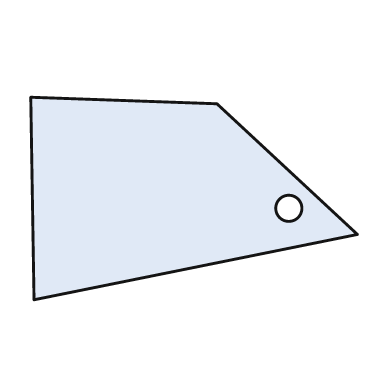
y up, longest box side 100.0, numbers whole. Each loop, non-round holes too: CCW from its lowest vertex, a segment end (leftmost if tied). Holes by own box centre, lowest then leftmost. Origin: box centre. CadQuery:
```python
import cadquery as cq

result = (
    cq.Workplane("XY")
    .moveTo(-49.0, -31.0)
    .lineTo(50.0, -11.0)
    .lineTo(7.0, 29.0)
    .lineTo(-50.0, 31.0)
    .close()
    .moveTo(29.0, -3.0)
    .circle(4.0)
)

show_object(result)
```